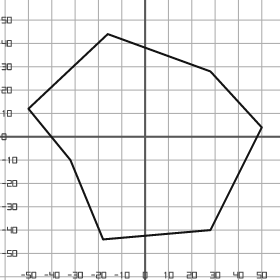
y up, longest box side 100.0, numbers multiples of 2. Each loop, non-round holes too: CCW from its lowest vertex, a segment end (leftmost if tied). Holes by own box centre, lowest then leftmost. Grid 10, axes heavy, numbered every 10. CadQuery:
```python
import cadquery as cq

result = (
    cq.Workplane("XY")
    .moveTo(-18.0, -44.0)
    .lineTo(28.0, -40.0)
    .lineTo(50.0, 4.0)
    .lineTo(28.0, 28.0)
    .lineTo(-16.0, 44.0)
    .lineTo(-50.0, 12.0)
    .lineTo(-32.0, -10.0)
    .close()
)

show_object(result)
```